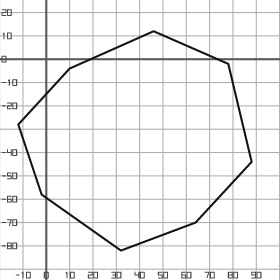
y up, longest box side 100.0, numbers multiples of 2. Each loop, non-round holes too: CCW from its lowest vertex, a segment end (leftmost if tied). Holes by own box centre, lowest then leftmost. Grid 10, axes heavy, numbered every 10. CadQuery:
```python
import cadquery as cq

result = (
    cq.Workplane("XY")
    .moveTo(32.0, -82.0)
    .lineTo(64.0, -70.0)
    .lineTo(88.0, -44.0)
    .lineTo(78.0, -2.0)
    .lineTo(46.0, 12.0)
    .lineTo(10.0, -4.0)
    .lineTo(-12.0, -28.0)
    .lineTo(-2.0, -58.0)
    .close()
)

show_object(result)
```